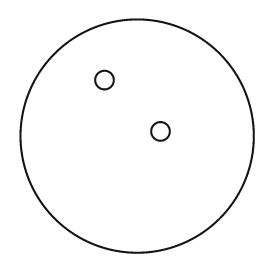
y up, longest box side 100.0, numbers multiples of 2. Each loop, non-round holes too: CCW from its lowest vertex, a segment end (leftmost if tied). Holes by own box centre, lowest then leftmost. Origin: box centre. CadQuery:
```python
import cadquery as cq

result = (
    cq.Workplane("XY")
    .moveTo(0.0, 0.0)
    .circle(50.0)
    .moveTo(10.0, 2.0)
    .circle(4.0)
    .moveTo(-14.0, 24.0)
    .circle(4.0)
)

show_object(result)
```